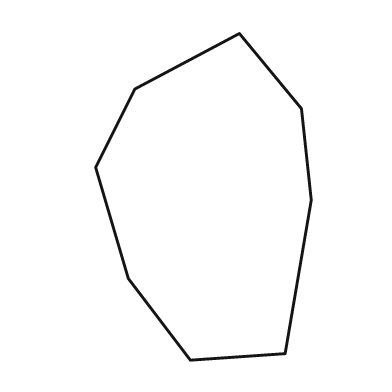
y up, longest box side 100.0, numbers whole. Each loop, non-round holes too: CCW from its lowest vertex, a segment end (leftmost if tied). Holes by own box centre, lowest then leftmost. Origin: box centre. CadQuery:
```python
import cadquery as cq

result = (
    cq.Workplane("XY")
    .moveTo(-4.0, -50.0)
    .lineTo(25.0, -48.0)
    .lineTo(33.0, -1.0)
    .lineTo(30.0, 27.0)
    .lineTo(11.0, 50.0)
    .lineTo(-21.0, 33.0)
    .lineTo(-33.0, 9.0)
    .lineTo(-23.0, -25.0)
    .close()
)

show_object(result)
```